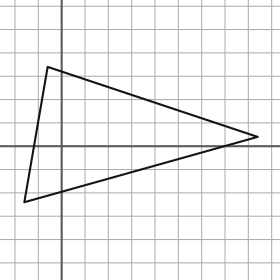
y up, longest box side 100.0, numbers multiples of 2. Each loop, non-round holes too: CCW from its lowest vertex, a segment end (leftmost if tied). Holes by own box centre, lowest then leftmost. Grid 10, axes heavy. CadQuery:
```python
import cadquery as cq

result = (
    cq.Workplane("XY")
    .moveTo(-16.0, -24.0)
    .lineTo(84.0, 4.0)
    .lineTo(-6.0, 34.0)
    .close()
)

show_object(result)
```